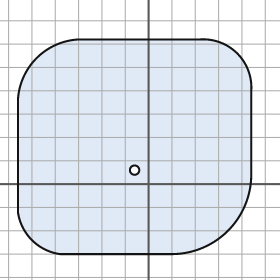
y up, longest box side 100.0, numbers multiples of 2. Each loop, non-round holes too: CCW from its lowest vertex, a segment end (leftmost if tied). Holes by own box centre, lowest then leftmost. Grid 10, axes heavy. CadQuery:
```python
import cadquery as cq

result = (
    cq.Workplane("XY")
    .moveTo(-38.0, -30.0)
    .lineTo(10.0, -30.0)
    .threePointArc((34.0, -20.0), (44.0, 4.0))
    .lineTo(44.0, 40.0)
    .threePointArc((38.0, 56.0), (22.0, 62.0))
    .lineTo(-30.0, 62.0)
    .threePointArc((-48.0, 54.0), (-56.0, 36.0))
    .lineTo(-56.0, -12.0)
    .threePointArc((-50.0, -24.0), (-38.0, -30.0))
    .close()
    .moveTo(-6.0, 6.0)
    .circle(2.0)
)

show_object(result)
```